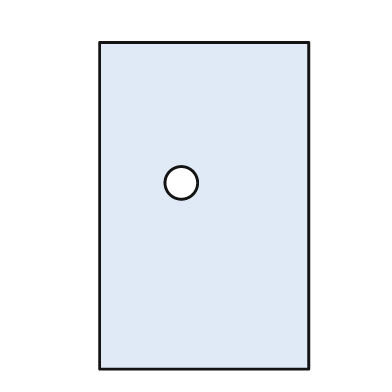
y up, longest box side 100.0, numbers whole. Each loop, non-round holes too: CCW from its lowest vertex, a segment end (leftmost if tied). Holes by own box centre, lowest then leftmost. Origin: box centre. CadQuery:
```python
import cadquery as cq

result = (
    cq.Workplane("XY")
    .moveTo(-32.0, -50.0)
    .lineTo(32.0, -50.0)
    .lineTo(32.0, 50.0)
    .lineTo(-32.0, 50.0)
    .close()
    .moveTo(-7.0, 7.0)
    .circle(5.0)
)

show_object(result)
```